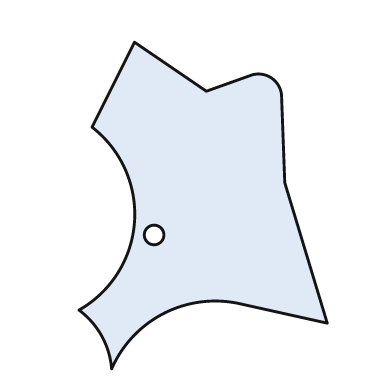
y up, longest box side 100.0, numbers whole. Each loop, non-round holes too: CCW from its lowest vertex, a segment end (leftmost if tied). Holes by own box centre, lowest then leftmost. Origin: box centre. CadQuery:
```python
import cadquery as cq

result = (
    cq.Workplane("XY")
    .moveTo(-28.0, -50.0)
    .threePointArc((-12.0, -33.0), (11.0, -30.0))
    .lineTo(38.0, -36.0)
    .lineTo(25.0, 7.0)
    .lineTo(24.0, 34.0)
    .threePointArc((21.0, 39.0), (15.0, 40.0))
    .lineTo(1.0, 35.0)
    .lineTo(-21.0, 50.0)
    .lineTo(-34.0, 24.0)
    .threePointArc((-21.0, -5.0), (-38.0, -32.0))
    .threePointArc((-31.0, -40.0), (-28.0, -50.0))
    .close()
    .moveTo(-15.0, -9.0)
    .circle(3.0)
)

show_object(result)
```